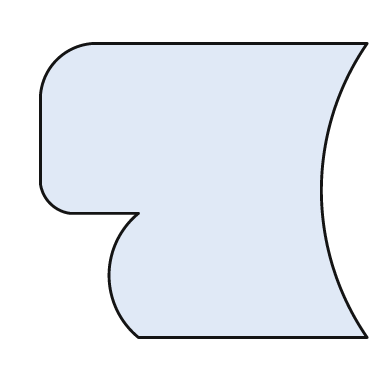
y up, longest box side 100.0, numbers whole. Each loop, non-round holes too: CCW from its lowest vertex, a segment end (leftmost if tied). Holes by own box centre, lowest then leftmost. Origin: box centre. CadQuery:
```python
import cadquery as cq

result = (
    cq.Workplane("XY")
    .moveTo(-20.0, -45.0)
    .lineTo(50.0, -45.0)
    .threePointArc((36.0, 0.0), (50.0, 45.0))
    .lineTo(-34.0, 45.0)
    .threePointArc((-45.0, 40.0), (-50.0, 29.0))
    .lineTo(-50.0, 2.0)
    .threePointArc((-47.0, -4.0), (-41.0, -7.0))
    .lineTo(-20.0, -7.0)
    .threePointArc((-29.0, -26.0), (-20.0, -45.0))
    .close()
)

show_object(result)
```